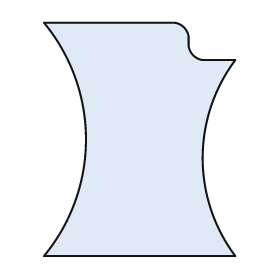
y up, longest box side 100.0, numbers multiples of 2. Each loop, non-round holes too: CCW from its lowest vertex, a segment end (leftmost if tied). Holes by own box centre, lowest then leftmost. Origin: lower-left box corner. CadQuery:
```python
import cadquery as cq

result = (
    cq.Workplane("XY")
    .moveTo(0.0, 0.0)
    .lineTo(82.0, 0.0)
    .threePointArc((68.0, 42.0), (82.0, 84.0))
    .lineTo(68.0, 84.0)
    .threePointArc((64.0, 86.0), (62.0, 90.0))
    .lineTo(62.0, 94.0)
    .threePointArc((60.0, 98.0), (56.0, 100.0))
    .lineTo(0.0, 100.0)
    .threePointArc((18.0, 50.0), (0.0, 0.0))
    .close()
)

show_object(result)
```